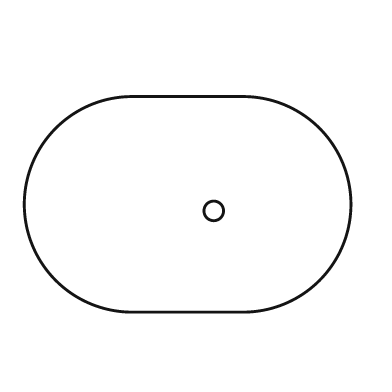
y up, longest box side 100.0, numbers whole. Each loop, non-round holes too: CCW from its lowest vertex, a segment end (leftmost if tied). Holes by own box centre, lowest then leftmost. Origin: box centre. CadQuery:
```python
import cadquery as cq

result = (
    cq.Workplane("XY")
    .moveTo(-17.0, -33.0)
    .lineTo(17.0, -33.0)
    .threePointArc((50.0, 0.0), (17.0, 33.0))
    .lineTo(-17.0, 33.0)
    .threePointArc((-50.0, 0.0), (-17.0, -33.0))
    .close()
    .moveTo(8.0, -2.0)
    .circle(3.0)
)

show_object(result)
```